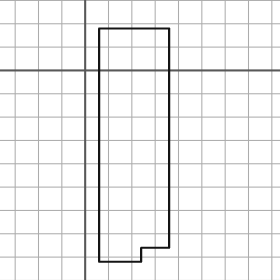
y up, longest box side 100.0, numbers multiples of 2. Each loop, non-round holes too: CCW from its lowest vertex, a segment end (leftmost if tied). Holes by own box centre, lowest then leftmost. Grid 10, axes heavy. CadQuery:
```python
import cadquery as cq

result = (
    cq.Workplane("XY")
    .moveTo(6.0, -82.0)
    .lineTo(24.0, -82.0)
    .lineTo(24.0, -76.0)
    .lineTo(36.0, -76.0)
    .lineTo(36.0, 18.0)
    .lineTo(6.0, 18.0)
    .close()
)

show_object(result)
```